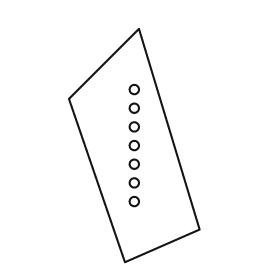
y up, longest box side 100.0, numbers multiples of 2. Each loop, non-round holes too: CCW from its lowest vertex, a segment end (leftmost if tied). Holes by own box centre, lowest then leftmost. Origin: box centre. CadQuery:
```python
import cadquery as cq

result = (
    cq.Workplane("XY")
    .moveTo(-4.0, -50.0)
    .lineTo(28.0, -36.0)
    .lineTo(2.0, 50.0)
    .lineTo(-28.0, 20.0)
    .close()
    .moveTo(0.0, -24.0)
    .circle(2.0)
    .moveTo(0.0, -16.0)
    .circle(2.0)
    .moveTo(0.0, -8.0)
    .circle(2.0)
    .moveTo(0.0, 0.0)
    .circle(2.0)
    .moveTo(0.0, 8.0)
    .circle(2.0)
    .moveTo(0.0, 16.0)
    .circle(2.0)
    .moveTo(0.0, 24.0)
    .circle(2.0)
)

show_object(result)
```